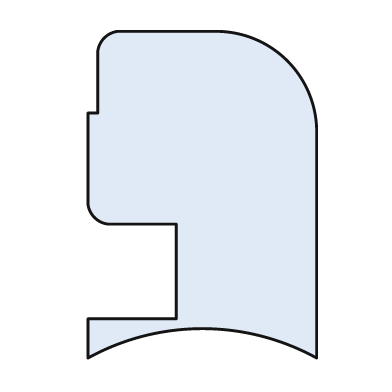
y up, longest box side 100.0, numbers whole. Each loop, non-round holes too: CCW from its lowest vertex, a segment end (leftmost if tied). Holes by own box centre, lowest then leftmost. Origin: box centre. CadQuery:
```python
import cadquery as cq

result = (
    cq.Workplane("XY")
    .moveTo(-35.0, -50.0)
    .threePointArc((0.0, -41.0), (35.0, -50.0))
    .lineTo(35.0, 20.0)
    .threePointArc((26.0, 41.0), (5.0, 50.0))
    .lineTo(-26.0, 50.0)
    .threePointArc((-30.0, 48.0), (-32.0, 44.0))
    .lineTo(-32.0, 25.0)
    .lineTo(-35.0, 25.0)
    .lineTo(-35.0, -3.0)
    .threePointArc((-33.0, -7.0), (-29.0, -9.0))
    .lineTo(-8.0, -9.0)
    .lineTo(-8.0, -38.0)
    .lineTo(-35.0, -38.0)
    .close()
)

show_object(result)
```